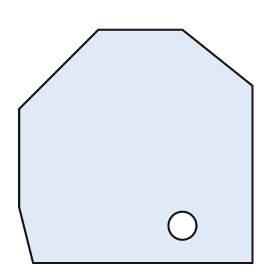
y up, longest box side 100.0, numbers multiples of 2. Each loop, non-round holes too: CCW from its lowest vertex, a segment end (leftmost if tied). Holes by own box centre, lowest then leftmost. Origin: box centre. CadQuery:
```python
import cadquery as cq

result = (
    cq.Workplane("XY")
    .moveTo(-44.0, -50.0)
    .lineTo(50.0, -50.0)
    .lineTo(50.0, 26.0)
    .lineTo(20.0, 50.0)
    .lineTo(-16.0, 50.0)
    .lineTo(-50.0, 16.0)
    .lineTo(-50.0, -26.0)
    .close()
    .moveTo(20.0, -34.0)
    .circle(6.0)
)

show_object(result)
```